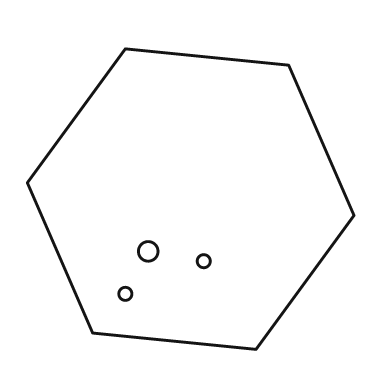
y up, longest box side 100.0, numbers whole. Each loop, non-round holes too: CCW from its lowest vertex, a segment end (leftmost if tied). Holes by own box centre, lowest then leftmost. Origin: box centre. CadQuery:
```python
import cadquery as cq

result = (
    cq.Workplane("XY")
    .moveTo(20.0, -46.0)
    .lineTo(50.0, -5.0)
    .lineTo(30.0, 41.0)
    .lineTo(-20.0, 46.0)
    .lineTo(-50.0, 5.0)
    .lineTo(-30.0, -41.0)
    .close()
    .moveTo(-20.0, -29.0)
    .circle(2.0)
    .moveTo(4.0, -19.0)
    .circle(2.0)
    .moveTo(-13.0, -16.0)
    .circle(3.0)
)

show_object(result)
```